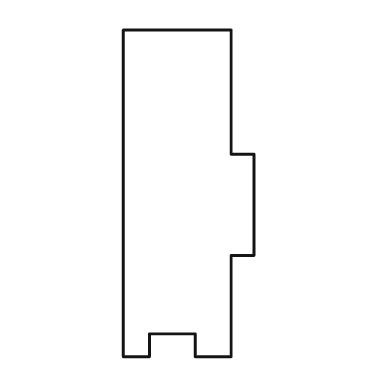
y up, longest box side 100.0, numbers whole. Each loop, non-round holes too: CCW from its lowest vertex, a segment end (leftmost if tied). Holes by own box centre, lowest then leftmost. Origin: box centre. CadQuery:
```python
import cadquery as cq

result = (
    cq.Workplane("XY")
    .moveTo(-20.0, -50.0)
    .lineTo(-12.0, -50.0)
    .lineTo(-12.0, -43.0)
    .lineTo(2.0, -43.0)
    .lineTo(2.0, -50.0)
    .lineTo(13.0, -50.0)
    .lineTo(13.0, -19.0)
    .lineTo(20.0, -19.0)
    .lineTo(20.0, 12.0)
    .lineTo(13.0, 12.0)
    .lineTo(13.0, 50.0)
    .lineTo(-20.0, 50.0)
    .close()
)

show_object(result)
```